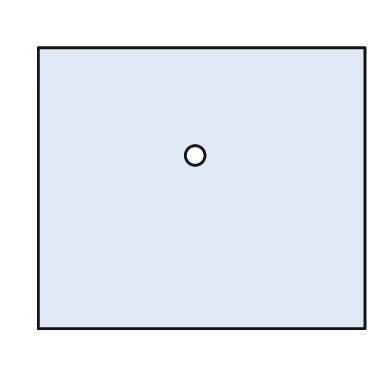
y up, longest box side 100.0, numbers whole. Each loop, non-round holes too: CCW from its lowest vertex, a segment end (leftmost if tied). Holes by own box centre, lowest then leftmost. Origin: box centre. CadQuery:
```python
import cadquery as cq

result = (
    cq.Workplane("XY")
    .moveTo(-50.0, -43.0)
    .lineTo(50.0, -43.0)
    .lineTo(50.0, 43.0)
    .lineTo(-50.0, 43.0)
    .close()
    .moveTo(-2.0, 10.0)
    .circle(3.0)
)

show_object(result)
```